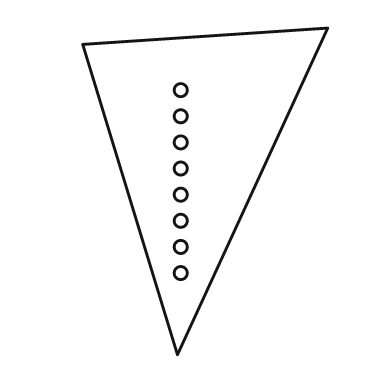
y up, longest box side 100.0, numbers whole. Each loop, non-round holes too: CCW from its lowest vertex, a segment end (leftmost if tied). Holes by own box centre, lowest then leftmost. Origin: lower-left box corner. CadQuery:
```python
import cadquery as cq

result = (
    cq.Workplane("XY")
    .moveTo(29.0, 0.0)
    .lineTo(75.0, 100.0)
    .lineTo(0.0, 95.0)
    .close()
    .moveTo(30.0, 25.0)
    .circle(2.0)
    .moveTo(30.0, 33.0)
    .circle(2.0)
    .moveTo(30.0, 41.0)
    .circle(2.0)
    .moveTo(30.0, 49.0)
    .circle(2.0)
    .moveTo(30.0, 57.0)
    .circle(2.0)
    .moveTo(30.0, 65.0)
    .circle(2.0)
    .moveTo(30.0, 73.0)
    .circle(2.0)
    .moveTo(30.0, 81.0)
    .circle(2.0)
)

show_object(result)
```